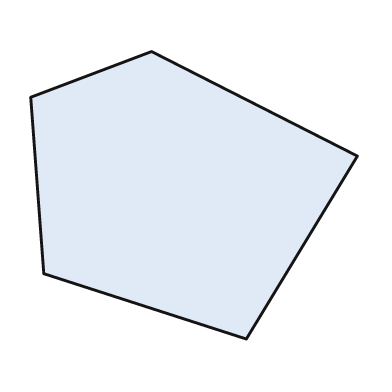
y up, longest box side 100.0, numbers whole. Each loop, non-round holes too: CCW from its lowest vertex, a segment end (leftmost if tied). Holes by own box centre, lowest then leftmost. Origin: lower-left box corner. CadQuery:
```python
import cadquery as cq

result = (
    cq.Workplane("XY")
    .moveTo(66.0, 0.0)
    .lineTo(100.0, 56.0)
    .lineTo(37.0, 88.0)
    .lineTo(0.0, 74.0)
    .lineTo(4.0, 20.0)
    .close()
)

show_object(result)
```